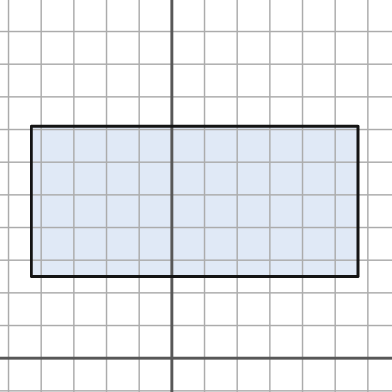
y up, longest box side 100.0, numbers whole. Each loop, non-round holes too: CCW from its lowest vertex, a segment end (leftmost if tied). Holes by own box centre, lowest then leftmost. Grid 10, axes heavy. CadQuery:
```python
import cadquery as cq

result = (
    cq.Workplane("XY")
    .moveTo(-43.0, 25.0)
    .lineTo(57.0, 25.0)
    .lineTo(57.0, 71.0)
    .lineTo(-43.0, 71.0)
    .close()
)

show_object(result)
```